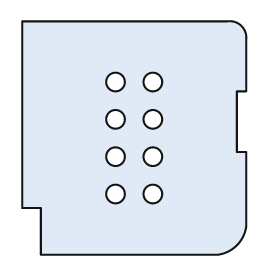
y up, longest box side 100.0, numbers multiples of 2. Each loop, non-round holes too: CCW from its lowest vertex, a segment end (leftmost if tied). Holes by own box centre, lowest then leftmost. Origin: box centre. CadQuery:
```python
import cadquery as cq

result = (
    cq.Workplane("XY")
    .moveTo(-40.0, -50.0)
    .lineTo(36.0, -50.0)
    .threePointArc((44.0, -46.0), (48.0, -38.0))
    .lineTo(48.0, -6.0)
    .lineTo(44.0, -6.0)
    .lineTo(44.0, 20.0)
    .lineTo(48.0, 20.0)
    .lineTo(48.0, 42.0)
    .threePointArc((46.0, 48.0), (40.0, 50.0))
    .lineTo(-48.0, 50.0)
    .lineTo(-48.0, -30.0)
    .lineTo(-40.0, -30.0)
    .close()
    .moveTo(-8.0, -24.0)
    .circle(4.0)
    .moveTo(8.0, -24.0)
    .circle(4.0)
    .moveTo(-8.0, -8.0)
    .circle(4.0)
    .moveTo(8.0, -8.0)
    .circle(4.0)
    .moveTo(-8.0, 8.0)
    .circle(4.0)
    .moveTo(8.0, 8.0)
    .circle(4.0)
    .moveTo(-8.0, 24.0)
    .circle(4.0)
    .moveTo(8.0, 24.0)
    .circle(4.0)
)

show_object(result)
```